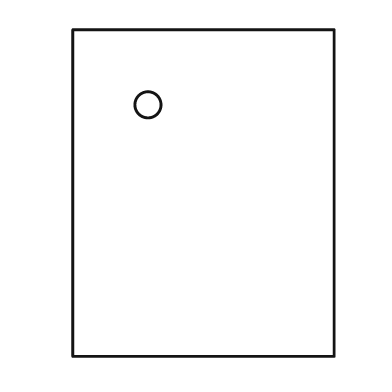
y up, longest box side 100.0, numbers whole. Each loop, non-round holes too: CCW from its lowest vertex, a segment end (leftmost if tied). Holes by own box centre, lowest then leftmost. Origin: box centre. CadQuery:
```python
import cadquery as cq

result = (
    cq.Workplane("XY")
    .moveTo(-40.0, -50.0)
    .lineTo(40.0, -50.0)
    .lineTo(40.0, 50.0)
    .lineTo(-40.0, 50.0)
    .close()
    .moveTo(-17.0, 27.0)
    .circle(4.0)
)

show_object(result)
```